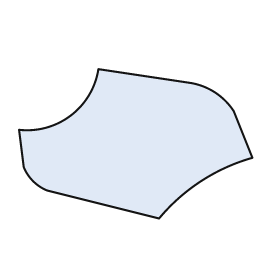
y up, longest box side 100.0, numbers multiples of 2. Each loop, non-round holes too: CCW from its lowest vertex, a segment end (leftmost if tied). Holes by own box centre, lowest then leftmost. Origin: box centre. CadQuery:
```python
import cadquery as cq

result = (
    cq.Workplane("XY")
    .moveTo(10.0, -32.0)
    .threePointArc((28.0, -16.0), (50.0, -6.0))
    .lineTo(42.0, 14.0)
    .threePointArc((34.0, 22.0), (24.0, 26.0))
    .lineTo(-16.0, 32.0)
    .threePointArc((-28.0, 12.0), (-50.0, 6.0))
    .lineTo(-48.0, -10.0)
    .threePointArc((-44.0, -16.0), (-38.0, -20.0))
    .close()
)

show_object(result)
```